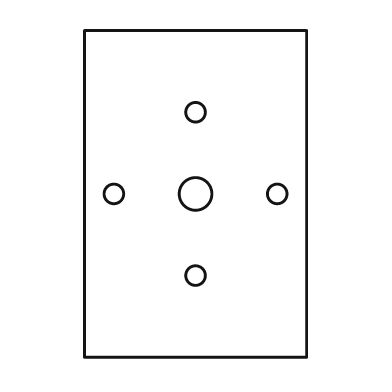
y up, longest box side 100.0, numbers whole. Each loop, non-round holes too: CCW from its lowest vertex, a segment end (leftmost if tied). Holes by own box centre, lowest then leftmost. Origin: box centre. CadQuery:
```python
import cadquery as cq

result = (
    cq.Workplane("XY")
    .moveTo(-34.0, -50.0)
    .lineTo(34.0, -50.0)
    .lineTo(34.0, 50.0)
    .lineTo(-34.0, 50.0)
    .close()
    .moveTo(0.0, -25.0)
    .circle(3.0)
    .moveTo(-25.0, 0.0)
    .circle(3.0)
    .moveTo(0.0, 0.0)
    .circle(5.0)
    .moveTo(25.0, 0.0)
    .circle(3.0)
    .moveTo(0.0, 25.0)
    .circle(3.0)
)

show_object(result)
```